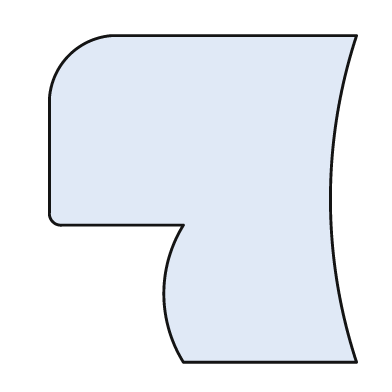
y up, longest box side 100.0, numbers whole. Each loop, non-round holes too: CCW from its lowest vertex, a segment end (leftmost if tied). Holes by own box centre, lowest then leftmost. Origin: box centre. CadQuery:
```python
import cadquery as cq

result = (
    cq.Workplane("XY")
    .moveTo(-6.0, -50.0)
    .lineTo(47.0, -50.0)
    .threePointArc((39.0, 0.0), (47.0, 50.0))
    .lineTo(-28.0, 50.0)
    .threePointArc((-41.0, 44.0), (-47.0, 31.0))
    .lineTo(-47.0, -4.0)
    .threePointArc((-46.0, -7.0), (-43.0, -8.0))
    .lineTo(-6.0, -8.0)
    .threePointArc((-12.0, -29.0), (-6.0, -50.0))
    .close()
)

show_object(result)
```